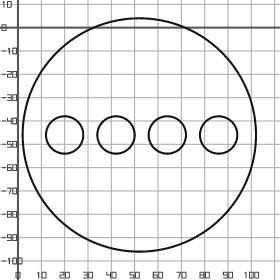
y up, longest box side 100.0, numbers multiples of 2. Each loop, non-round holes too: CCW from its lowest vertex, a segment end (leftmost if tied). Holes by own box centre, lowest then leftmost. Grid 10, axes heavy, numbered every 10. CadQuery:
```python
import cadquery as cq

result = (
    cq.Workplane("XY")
    .moveTo(52.0, -46.0)
    .circle(50.0)
    .moveTo(20.0, -46.0)
    .circle(8.0)
    .moveTo(42.0, -46.0)
    .circle(8.0)
    .moveTo(64.0, -46.0)
    .circle(8.0)
    .moveTo(86.0, -46.0)
    .circle(8.0)
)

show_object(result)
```